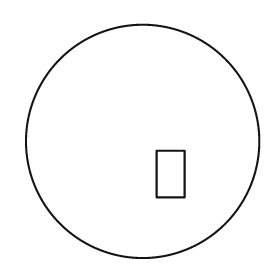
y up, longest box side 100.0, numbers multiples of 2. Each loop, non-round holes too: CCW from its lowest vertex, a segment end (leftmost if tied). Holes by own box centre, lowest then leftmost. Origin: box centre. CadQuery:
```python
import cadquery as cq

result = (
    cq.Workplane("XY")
    .moveTo(0.0, 0.0)
    .circle(50.0)
    .moveTo(6.0, -24.0)
    .lineTo(18.0, -24.0)
    .lineTo(18.0, -4.0)
    .lineTo(6.0, -4.0)
    .close()
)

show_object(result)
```